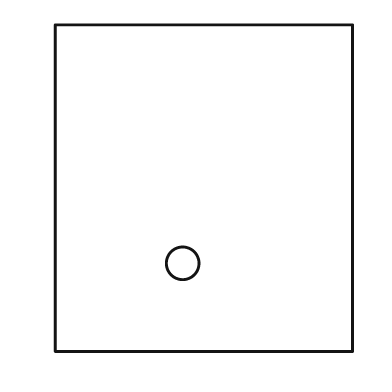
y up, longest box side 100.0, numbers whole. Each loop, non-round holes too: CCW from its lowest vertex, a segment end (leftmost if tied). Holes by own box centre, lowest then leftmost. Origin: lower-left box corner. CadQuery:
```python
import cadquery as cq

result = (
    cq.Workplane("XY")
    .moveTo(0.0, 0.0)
    .lineTo(91.0, 0.0)
    .lineTo(91.0, 100.0)
    .lineTo(0.0, 100.0)
    .close()
    .moveTo(39.0, 27.0)
    .circle(5.0)
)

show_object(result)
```